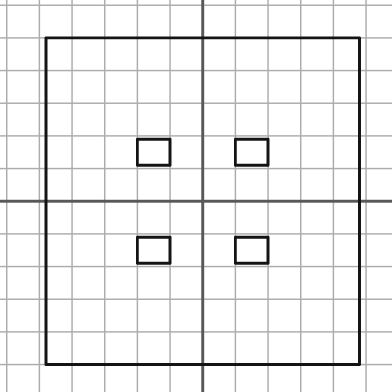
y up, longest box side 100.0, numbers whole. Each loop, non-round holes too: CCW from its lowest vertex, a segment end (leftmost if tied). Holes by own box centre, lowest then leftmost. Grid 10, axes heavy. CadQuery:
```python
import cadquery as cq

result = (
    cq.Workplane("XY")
    .moveTo(-48.0, -50.0)
    .lineTo(48.0, -50.0)
    .lineTo(48.0, 50.0)
    .lineTo(-48.0, 50.0)
    .close()
    .moveTo(-20.0, -19.0)
    .lineTo(-10.0, -19.0)
    .lineTo(-10.0, -11.0)
    .lineTo(-20.0, -11.0)
    .close()
    .moveTo(10.0, -19.0)
    .lineTo(20.0, -19.0)
    .lineTo(20.0, -11.0)
    .lineTo(10.0, -11.0)
    .close()
    .moveTo(-20.0, 11.0)
    .lineTo(-10.0, 11.0)
    .lineTo(-10.0, 19.0)
    .lineTo(-20.0, 19.0)
    .close()
    .moveTo(10.0, 11.0)
    .lineTo(20.0, 11.0)
    .lineTo(20.0, 19.0)
    .lineTo(10.0, 19.0)
    .close()
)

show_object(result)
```